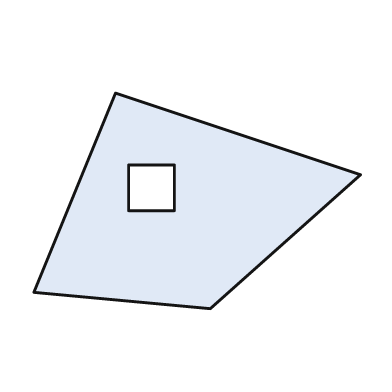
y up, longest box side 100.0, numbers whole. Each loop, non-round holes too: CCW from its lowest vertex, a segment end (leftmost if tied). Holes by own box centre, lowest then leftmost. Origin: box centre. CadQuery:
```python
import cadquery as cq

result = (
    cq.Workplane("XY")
    .moveTo(4.0, -33.0)
    .lineTo(50.0, 8.0)
    .lineTo(-25.0, 33.0)
    .lineTo(-50.0, -28.0)
    .close()
    .moveTo(-21.0, -3.0)
    .lineTo(-7.0, -3.0)
    .lineTo(-7.0, 11.0)
    .lineTo(-21.0, 11.0)
    .close()
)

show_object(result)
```